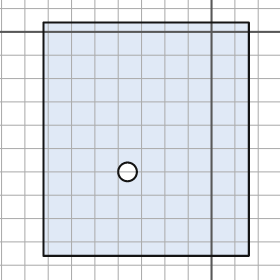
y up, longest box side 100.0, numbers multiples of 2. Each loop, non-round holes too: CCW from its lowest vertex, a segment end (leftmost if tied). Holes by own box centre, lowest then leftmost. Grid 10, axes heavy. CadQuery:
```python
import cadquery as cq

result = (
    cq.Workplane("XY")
    .moveTo(-72.0, -96.0)
    .lineTo(16.0, -96.0)
    .lineTo(16.0, 4.0)
    .lineTo(-72.0, 4.0)
    .close()
    .moveTo(-36.0, -60.0)
    .circle(4.0)
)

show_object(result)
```